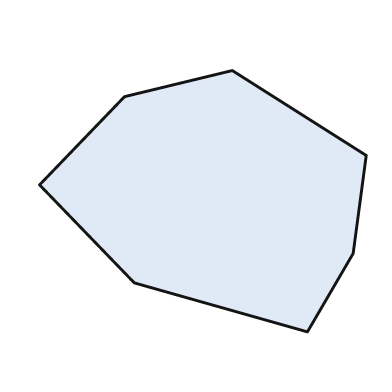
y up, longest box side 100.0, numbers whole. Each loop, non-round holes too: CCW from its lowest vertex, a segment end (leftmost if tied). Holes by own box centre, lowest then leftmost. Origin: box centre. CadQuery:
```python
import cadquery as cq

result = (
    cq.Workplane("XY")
    .moveTo(32.0, -40.0)
    .lineTo(46.0, -16.0)
    .lineTo(50.0, 14.0)
    .lineTo(9.0, 40.0)
    .lineTo(-24.0, 32.0)
    .lineTo(-50.0, 5.0)
    .lineTo(-21.0, -25.0)
    .close()
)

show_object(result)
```